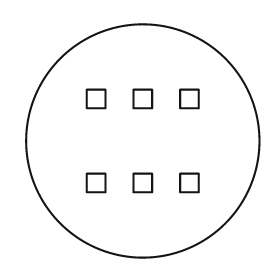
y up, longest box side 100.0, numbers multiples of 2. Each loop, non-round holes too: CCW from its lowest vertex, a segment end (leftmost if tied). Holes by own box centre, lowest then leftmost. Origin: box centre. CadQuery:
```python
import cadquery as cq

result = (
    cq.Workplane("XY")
    .moveTo(0.0, 0.0)
    .circle(50.0)
    .moveTo(-24.0, -22.0)
    .lineTo(-16.0, -22.0)
    .lineTo(-16.0, -14.0)
    .lineTo(-24.0, -14.0)
    .close()
    .moveTo(-4.0, -22.0)
    .lineTo(4.0, -22.0)
    .lineTo(4.0, -14.0)
    .lineTo(-4.0, -14.0)
    .close()
    .moveTo(16.0, -22.0)
    .lineTo(24.0, -22.0)
    .lineTo(24.0, -14.0)
    .lineTo(16.0, -14.0)
    .close()
    .moveTo(-24.0, 14.0)
    .lineTo(-16.0, 14.0)
    .lineTo(-16.0, 22.0)
    .lineTo(-24.0, 22.0)
    .close()
    .moveTo(-4.0, 14.0)
    .lineTo(4.0, 14.0)
    .lineTo(4.0, 22.0)
    .lineTo(-4.0, 22.0)
    .close()
    .moveTo(16.0, 14.0)
    .lineTo(24.0, 14.0)
    .lineTo(24.0, 22.0)
    .lineTo(16.0, 22.0)
    .close()
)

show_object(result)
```